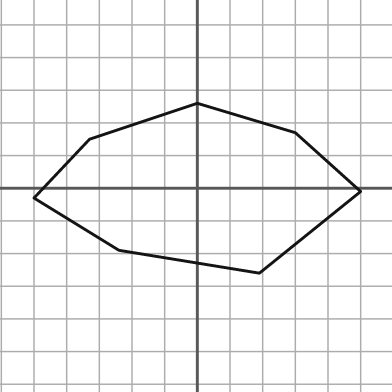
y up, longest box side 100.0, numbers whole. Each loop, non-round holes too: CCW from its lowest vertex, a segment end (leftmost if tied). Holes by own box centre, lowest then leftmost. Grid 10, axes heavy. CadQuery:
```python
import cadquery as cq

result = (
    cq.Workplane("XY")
    .moveTo(19.0, -26.0)
    .lineTo(50.0, -1.0)
    .lineTo(30.0, 17.0)
    .lineTo(0.0, 26.0)
    .lineTo(-33.0, 15.0)
    .lineTo(-50.0, -3.0)
    .lineTo(-24.0, -19.0)
    .close()
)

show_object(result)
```